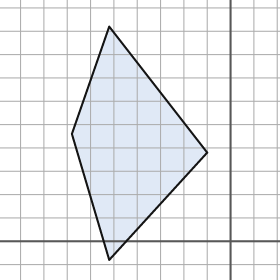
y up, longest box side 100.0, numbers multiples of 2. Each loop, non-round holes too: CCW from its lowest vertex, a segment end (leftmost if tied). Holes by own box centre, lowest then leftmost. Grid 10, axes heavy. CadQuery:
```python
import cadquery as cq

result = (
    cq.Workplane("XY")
    .moveTo(-52.0, -8.0)
    .lineTo(-10.0, 38.0)
    .lineTo(-52.0, 92.0)
    .lineTo(-68.0, 46.0)
    .close()
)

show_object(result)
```